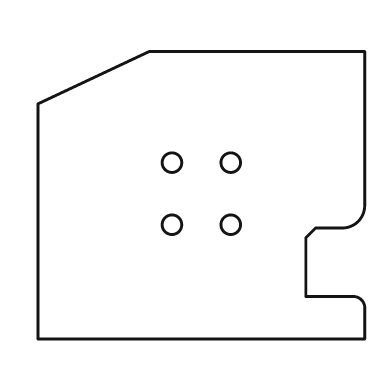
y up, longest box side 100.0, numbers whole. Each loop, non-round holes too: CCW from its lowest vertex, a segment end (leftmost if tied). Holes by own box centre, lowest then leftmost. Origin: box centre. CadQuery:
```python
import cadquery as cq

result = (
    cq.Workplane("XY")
    .moveTo(-50.0, -44.0)
    .lineTo(50.0, -44.0)
    .lineTo(50.0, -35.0)
    .threePointArc((49.0, -32.0), (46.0, -31.0))
    .lineTo(32.0, -31.0)
    .lineTo(32.0, -13.0)
    .lineTo(35.0, -10.0)
    .lineTo(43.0, -10.0)
    .threePointArc((48.0, -8.0), (50.0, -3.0))
    .lineTo(50.0, 44.0)
    .lineTo(-16.0, 44.0)
    .lineTo(-50.0, 28.0)
    .close()
    .moveTo(-9.0, -9.0)
    .circle(3.0)
    .moveTo(9.0, -9.0)
    .circle(3.0)
    .moveTo(-9.0, 10.0)
    .circle(3.0)
    .moveTo(9.0, 10.0)
    .circle(3.0)
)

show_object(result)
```